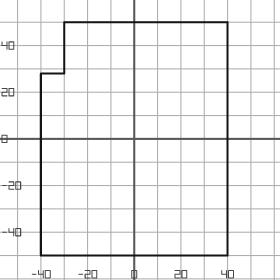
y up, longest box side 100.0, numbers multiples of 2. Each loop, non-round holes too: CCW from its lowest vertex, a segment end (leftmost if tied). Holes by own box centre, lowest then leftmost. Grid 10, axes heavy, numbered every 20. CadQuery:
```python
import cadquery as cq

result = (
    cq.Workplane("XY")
    .moveTo(-40.0, -50.0)
    .lineTo(40.0, -50.0)
    .lineTo(40.0, 50.0)
    .lineTo(-30.0, 50.0)
    .lineTo(-30.0, 28.0)
    .lineTo(-40.0, 28.0)
    .close()
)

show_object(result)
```